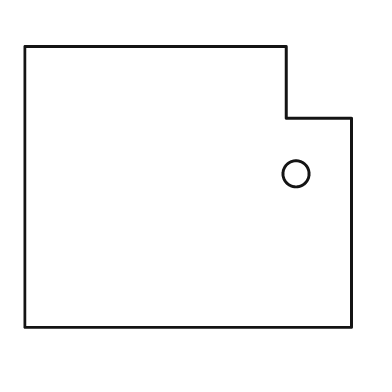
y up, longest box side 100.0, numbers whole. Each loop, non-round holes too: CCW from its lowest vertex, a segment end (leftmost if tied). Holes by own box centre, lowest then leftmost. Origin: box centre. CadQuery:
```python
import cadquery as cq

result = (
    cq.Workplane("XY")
    .moveTo(-50.0, -43.0)
    .lineTo(50.0, -43.0)
    .lineTo(50.0, 21.0)
    .lineTo(30.0, 21.0)
    .lineTo(30.0, 43.0)
    .lineTo(-50.0, 43.0)
    .close()
    .moveTo(33.0, 4.0)
    .circle(4.0)
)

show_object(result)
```